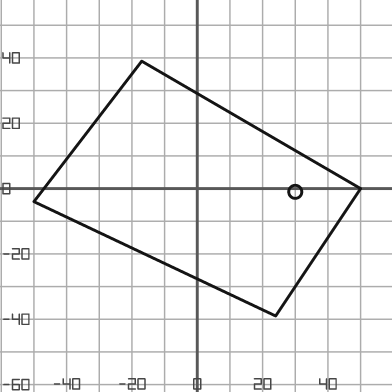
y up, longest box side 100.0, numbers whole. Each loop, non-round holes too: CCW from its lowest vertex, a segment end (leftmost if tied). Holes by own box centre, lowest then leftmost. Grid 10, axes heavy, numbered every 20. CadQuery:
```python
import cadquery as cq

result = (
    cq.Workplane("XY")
    .moveTo(24.0, -39.0)
    .lineTo(50.0, 0.0)
    .lineTo(-17.0, 39.0)
    .lineTo(-50.0, -4.0)
    .close()
    .moveTo(30.0, -1.0)
    .circle(2.0)
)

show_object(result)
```